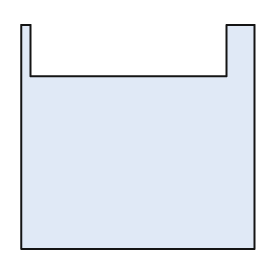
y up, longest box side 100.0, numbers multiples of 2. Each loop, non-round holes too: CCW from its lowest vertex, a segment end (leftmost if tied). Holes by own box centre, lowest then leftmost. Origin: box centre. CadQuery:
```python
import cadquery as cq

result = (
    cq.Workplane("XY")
    .moveTo(-50.0, -48.0)
    .lineTo(50.0, -48.0)
    .lineTo(50.0, 48.0)
    .lineTo(38.0, 48.0)
    .lineTo(38.0, 26.0)
    .lineTo(-46.0, 26.0)
    .lineTo(-46.0, 48.0)
    .lineTo(-50.0, 48.0)
    .close()
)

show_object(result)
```